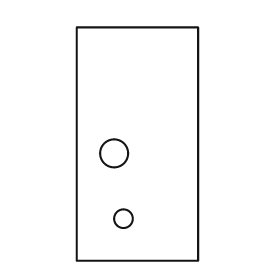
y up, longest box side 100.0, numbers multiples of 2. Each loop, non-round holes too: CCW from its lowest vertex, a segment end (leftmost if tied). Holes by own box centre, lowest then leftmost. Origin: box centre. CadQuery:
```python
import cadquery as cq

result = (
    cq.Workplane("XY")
    .moveTo(-26.0, -50.0)
    .lineTo(26.0, -50.0)
    .lineTo(26.0, 50.0)
    .lineTo(-26.0, 50.0)
    .close()
    .moveTo(-6.0, -32.0)
    .circle(4.0)
    .moveTo(-10.0, -4.0)
    .circle(6.0)
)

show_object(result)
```